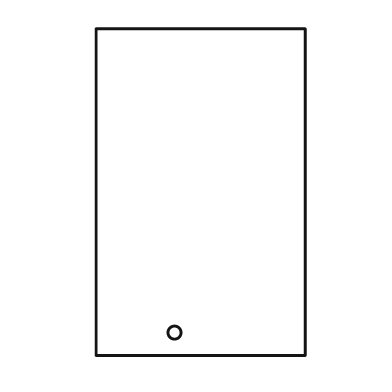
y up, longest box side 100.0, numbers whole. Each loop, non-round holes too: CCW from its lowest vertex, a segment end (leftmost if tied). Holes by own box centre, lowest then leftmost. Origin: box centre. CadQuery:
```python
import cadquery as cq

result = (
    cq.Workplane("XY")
    .moveTo(-32.0, -50.0)
    .lineTo(32.0, -50.0)
    .lineTo(32.0, 50.0)
    .lineTo(-32.0, 50.0)
    .close()
    .moveTo(-8.0, -43.0)
    .circle(2.0)
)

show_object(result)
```